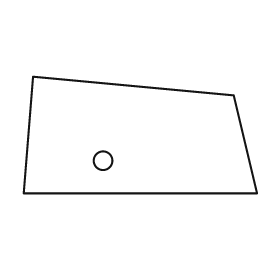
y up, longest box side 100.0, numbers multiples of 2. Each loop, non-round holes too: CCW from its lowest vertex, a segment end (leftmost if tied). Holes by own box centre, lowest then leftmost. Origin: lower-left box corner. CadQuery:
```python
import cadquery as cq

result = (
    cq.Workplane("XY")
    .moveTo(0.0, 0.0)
    .lineTo(100.0, 0.0)
    .lineTo(90.0, 42.0)
    .lineTo(4.0, 50.0)
    .close()
    .moveTo(34.0, 14.0)
    .circle(4.0)
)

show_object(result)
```